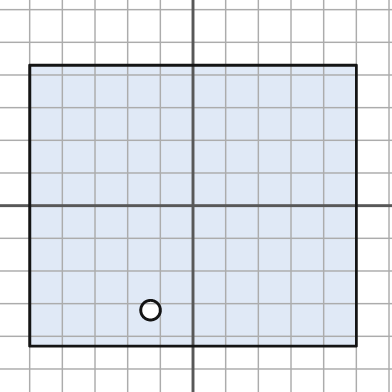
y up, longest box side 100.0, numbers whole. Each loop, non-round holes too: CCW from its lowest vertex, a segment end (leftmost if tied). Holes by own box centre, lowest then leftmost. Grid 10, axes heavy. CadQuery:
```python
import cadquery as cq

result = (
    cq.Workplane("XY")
    .moveTo(-50.0, -43.0)
    .lineTo(50.0, -43.0)
    .lineTo(50.0, 43.0)
    .lineTo(-50.0, 43.0)
    .close()
    .moveTo(-13.0, -32.0)
    .circle(3.0)
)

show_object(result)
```